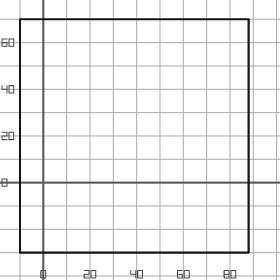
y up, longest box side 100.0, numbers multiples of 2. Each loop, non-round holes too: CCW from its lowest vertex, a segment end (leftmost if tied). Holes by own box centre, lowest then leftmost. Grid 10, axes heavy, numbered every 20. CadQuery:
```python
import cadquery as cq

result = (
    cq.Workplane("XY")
    .moveTo(-10.0, -30.0)
    .lineTo(88.0, -30.0)
    .lineTo(88.0, 70.0)
    .lineTo(-10.0, 70.0)
    .close()
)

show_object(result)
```